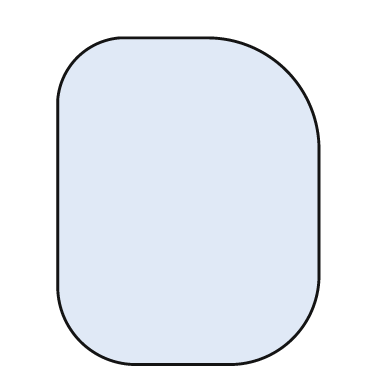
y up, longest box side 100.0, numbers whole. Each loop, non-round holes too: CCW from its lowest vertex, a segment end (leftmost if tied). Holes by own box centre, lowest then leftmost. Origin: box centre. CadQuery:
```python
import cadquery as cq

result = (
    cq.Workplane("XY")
    .moveTo(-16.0, -50.0)
    .lineTo(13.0, -50.0)
    .threePointArc((32.0, -42.0), (40.0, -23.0))
    .lineTo(40.0, 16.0)
    .threePointArc((30.0, 40.0), (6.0, 50.0))
    .lineTo(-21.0, 50.0)
    .threePointArc((-34.0, 44.0), (-40.0, 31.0))
    .lineTo(-40.0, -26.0)
    .threePointArc((-33.0, -43.0), (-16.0, -50.0))
    .close()
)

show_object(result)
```